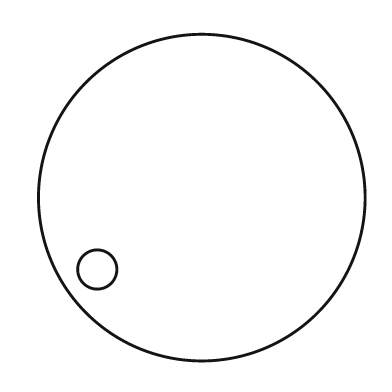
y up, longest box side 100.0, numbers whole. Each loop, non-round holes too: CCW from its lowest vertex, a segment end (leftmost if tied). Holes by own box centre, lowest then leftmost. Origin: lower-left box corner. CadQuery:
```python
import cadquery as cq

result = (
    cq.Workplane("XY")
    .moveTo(50.0, 50.0)
    .circle(50.0)
    .moveTo(18.0, 28.0)
    .circle(6.0)
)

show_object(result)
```